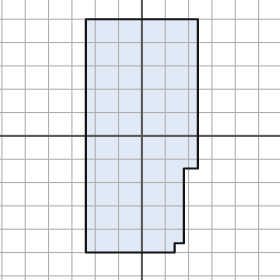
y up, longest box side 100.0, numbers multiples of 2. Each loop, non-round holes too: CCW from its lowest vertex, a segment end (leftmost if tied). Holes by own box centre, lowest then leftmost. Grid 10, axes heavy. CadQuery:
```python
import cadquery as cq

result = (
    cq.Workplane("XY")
    .moveTo(-24.0, -50.0)
    .lineTo(14.0, -50.0)
    .lineTo(14.0, -46.0)
    .lineTo(18.0, -46.0)
    .lineTo(18.0, -14.0)
    .lineTo(24.0, -14.0)
    .lineTo(24.0, 50.0)
    .lineTo(-24.0, 50.0)
    .close()
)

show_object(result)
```